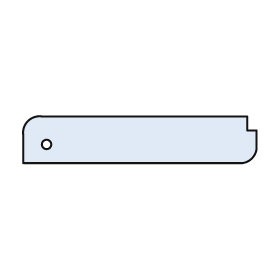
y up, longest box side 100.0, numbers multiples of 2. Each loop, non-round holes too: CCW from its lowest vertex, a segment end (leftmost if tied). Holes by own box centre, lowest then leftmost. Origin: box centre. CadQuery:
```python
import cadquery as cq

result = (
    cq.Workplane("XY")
    .moveTo(-50.0, -10.0)
    .lineTo(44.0, -10.0)
    .threePointArc((48.0, -8.0), (50.0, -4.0))
    .lineTo(50.0, 4.0)
    .lineTo(46.0, 4.0)
    .lineTo(46.0, 10.0)
    .lineTo(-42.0, 10.0)
    .threePointArc((-48.0, 8.0), (-50.0, 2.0))
    .close()
    .moveTo(-40.0, -2.0)
    .circle(2.0)
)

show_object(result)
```